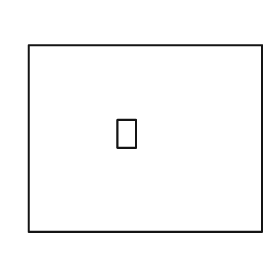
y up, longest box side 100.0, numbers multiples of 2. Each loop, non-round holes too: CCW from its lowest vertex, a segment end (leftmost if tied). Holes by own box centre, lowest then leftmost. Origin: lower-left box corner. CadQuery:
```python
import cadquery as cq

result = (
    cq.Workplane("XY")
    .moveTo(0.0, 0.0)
    .lineTo(100.0, 0.0)
    .lineTo(100.0, 80.0)
    .lineTo(0.0, 80.0)
    .close()
    .moveTo(38.0, 36.0)
    .lineTo(46.0, 36.0)
    .lineTo(46.0, 48.0)
    .lineTo(38.0, 48.0)
    .close()
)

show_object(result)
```